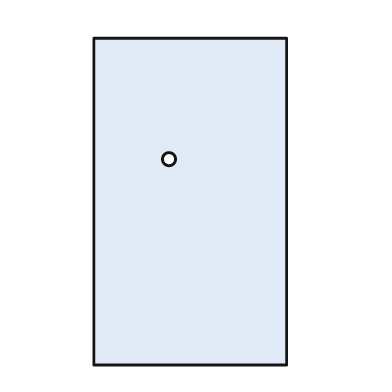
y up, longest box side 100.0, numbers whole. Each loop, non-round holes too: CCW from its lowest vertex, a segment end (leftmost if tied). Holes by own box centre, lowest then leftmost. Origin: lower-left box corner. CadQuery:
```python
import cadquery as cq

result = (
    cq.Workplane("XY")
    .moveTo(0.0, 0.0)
    .lineTo(59.0, 0.0)
    .lineTo(59.0, 100.0)
    .lineTo(0.0, 100.0)
    .close()
    .moveTo(23.0, 63.0)
    .circle(2.0)
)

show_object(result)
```